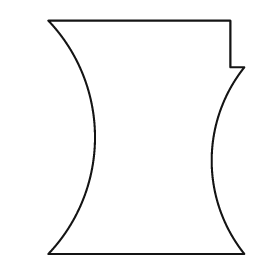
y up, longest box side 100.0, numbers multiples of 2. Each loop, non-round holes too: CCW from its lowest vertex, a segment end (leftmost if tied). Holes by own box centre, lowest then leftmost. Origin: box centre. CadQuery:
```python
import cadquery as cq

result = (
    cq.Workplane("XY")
    .moveTo(-42.0, -50.0)
    .lineTo(42.0, -50.0)
    .threePointArc((28.0, -10.0), (42.0, 30.0))
    .lineTo(36.0, 30.0)
    .lineTo(36.0, 50.0)
    .lineTo(-42.0, 50.0)
    .threePointArc((-22.0, 0.0), (-42.0, -50.0))
    .close()
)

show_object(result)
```